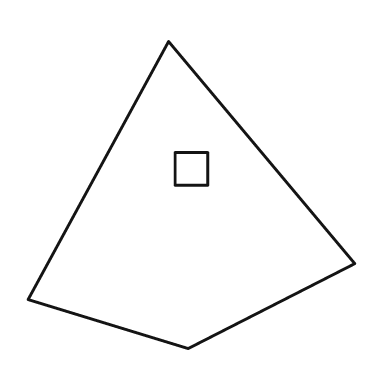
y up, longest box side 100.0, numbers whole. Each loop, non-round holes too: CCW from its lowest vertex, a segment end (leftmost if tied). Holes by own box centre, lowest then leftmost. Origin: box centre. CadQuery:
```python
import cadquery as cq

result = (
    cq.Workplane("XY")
    .moveTo(-1.0, -47.0)
    .lineTo(50.0, -21.0)
    .lineTo(-7.0, 47.0)
    .lineTo(-50.0, -32.0)
    .close()
    .moveTo(-5.0, 3.0)
    .lineTo(5.0, 3.0)
    .lineTo(5.0, 13.0)
    .lineTo(-5.0, 13.0)
    .close()
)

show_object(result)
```